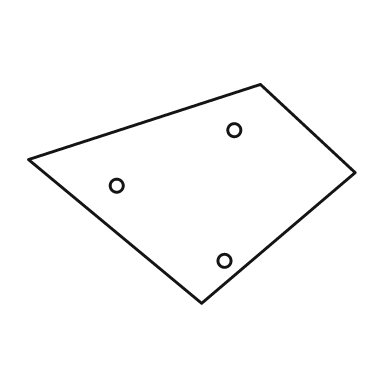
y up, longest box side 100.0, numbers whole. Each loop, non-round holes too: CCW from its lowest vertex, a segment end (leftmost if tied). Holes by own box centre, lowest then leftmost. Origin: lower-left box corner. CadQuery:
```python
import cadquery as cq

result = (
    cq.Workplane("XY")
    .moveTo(53.0, 0.0)
    .lineTo(100.0, 40.0)
    .lineTo(71.0, 67.0)
    .lineTo(0.0, 44.0)
    .close()
    .moveTo(60.0, 13.0)
    .circle(2.0)
    .moveTo(27.0, 36.0)
    .circle(2.0)
    .moveTo(63.0, 53.0)
    .circle(2.0)
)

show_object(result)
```